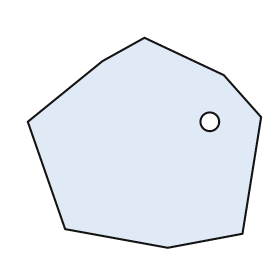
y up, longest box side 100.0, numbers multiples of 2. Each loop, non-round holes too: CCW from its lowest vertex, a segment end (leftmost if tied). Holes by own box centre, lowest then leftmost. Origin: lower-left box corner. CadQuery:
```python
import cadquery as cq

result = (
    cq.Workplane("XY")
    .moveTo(60.0, 0.0)
    .lineTo(92.0, 6.0)
    .lineTo(100.0, 56.0)
    .lineTo(84.0, 74.0)
    .lineTo(50.0, 90.0)
    .lineTo(32.0, 80.0)
    .lineTo(0.0, 54.0)
    .lineTo(16.0, 8.0)
    .close()
    .moveTo(78.0, 54.0)
    .circle(4.0)
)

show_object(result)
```